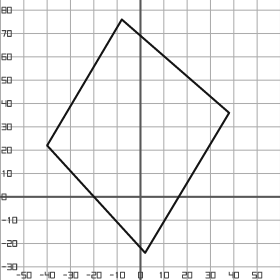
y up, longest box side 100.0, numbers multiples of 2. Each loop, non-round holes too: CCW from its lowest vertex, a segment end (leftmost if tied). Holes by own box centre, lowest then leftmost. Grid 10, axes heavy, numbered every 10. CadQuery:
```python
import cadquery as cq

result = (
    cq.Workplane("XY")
    .moveTo(2.0, -24.0)
    .lineTo(38.0, 36.0)
    .lineTo(-8.0, 76.0)
    .lineTo(-40.0, 22.0)
    .close()
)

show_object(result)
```